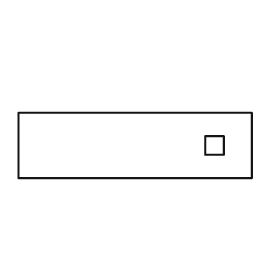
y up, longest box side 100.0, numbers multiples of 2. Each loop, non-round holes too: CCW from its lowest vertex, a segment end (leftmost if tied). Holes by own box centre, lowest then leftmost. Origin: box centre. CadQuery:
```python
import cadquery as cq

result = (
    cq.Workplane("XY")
    .moveTo(-50.0, -14.0)
    .lineTo(50.0, -14.0)
    .lineTo(50.0, 14.0)
    .lineTo(-50.0, 14.0)
    .close()
    .moveTo(30.0, -4.0)
    .lineTo(38.0, -4.0)
    .lineTo(38.0, 4.0)
    .lineTo(30.0, 4.0)
    .close()
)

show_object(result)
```